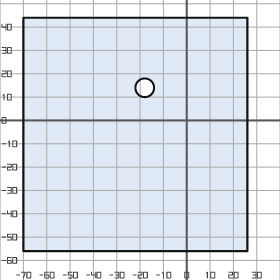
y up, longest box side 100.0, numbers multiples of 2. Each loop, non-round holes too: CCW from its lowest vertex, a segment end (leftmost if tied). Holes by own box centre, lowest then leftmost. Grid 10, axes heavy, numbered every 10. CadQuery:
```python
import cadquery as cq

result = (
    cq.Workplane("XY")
    .moveTo(-70.0, -56.0)
    .lineTo(26.0, -56.0)
    .lineTo(26.0, 44.0)
    .lineTo(-70.0, 44.0)
    .close()
    .moveTo(-18.0, 14.0)
    .circle(4.0)
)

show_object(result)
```